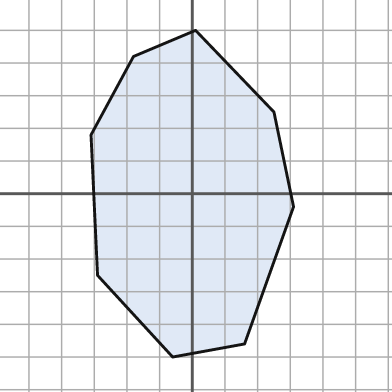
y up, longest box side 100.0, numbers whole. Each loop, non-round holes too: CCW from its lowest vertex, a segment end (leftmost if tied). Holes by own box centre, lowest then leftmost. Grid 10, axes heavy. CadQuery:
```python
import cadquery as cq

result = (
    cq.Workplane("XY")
    .moveTo(-6.0, -50.0)
    .lineTo(16.0, -46.0)
    .lineTo(31.0, -4.0)
    .lineTo(25.0, 25.0)
    .lineTo(1.0, 50.0)
    .lineTo(-18.0, 42.0)
    .lineTo(-31.0, 18.0)
    .lineTo(-29.0, -25.0)
    .close()
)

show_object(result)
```